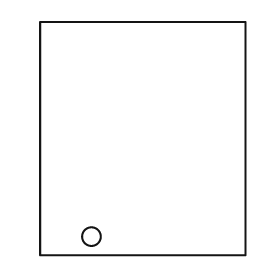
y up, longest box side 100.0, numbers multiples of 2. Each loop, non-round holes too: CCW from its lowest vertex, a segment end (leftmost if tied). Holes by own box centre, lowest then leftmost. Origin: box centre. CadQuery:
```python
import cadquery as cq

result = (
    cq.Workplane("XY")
    .moveTo(-44.0, -50.0)
    .lineTo(44.0, -50.0)
    .lineTo(44.0, 50.0)
    .lineTo(-44.0, 50.0)
    .close()
    .moveTo(-22.0, -42.0)
    .circle(4.0)
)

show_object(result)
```